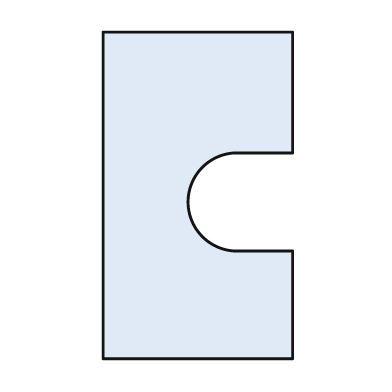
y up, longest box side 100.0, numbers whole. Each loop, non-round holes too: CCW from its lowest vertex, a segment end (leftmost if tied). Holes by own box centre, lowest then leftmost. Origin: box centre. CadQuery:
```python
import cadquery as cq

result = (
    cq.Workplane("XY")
    .moveTo(-29.0, -50.0)
    .lineTo(29.0, -50.0)
    .lineTo(29.0, -17.0)
    .lineTo(11.0, -17.0)
    .threePointArc((-3.0, -2.0), (11.0, 13.0))
    .lineTo(29.0, 13.0)
    .lineTo(29.0, 50.0)
    .lineTo(-29.0, 50.0)
    .close()
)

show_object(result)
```